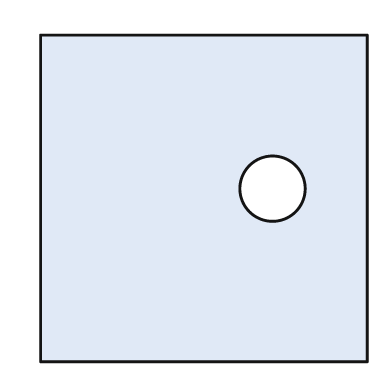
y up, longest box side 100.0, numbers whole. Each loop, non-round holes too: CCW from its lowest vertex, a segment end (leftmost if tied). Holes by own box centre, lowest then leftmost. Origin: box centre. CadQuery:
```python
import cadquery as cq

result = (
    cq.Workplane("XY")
    .moveTo(-50.0, -50.0)
    .lineTo(50.0, -50.0)
    .lineTo(50.0, 50.0)
    .lineTo(-50.0, 50.0)
    .close()
    .moveTo(21.0, 3.0)
    .circle(10.0)
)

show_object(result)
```